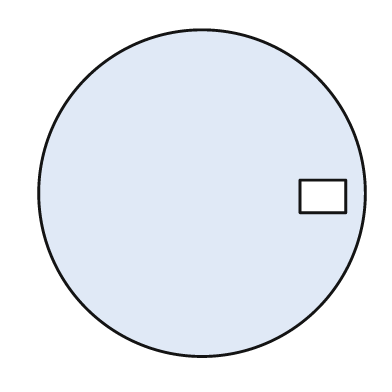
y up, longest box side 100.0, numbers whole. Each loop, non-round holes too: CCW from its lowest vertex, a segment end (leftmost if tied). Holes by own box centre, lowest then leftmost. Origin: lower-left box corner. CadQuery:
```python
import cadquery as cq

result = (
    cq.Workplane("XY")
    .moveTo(50.0, 50.0)
    .circle(50.0)
    .moveTo(80.0, 44.0)
    .lineTo(94.0, 44.0)
    .lineTo(94.0, 54.0)
    .lineTo(80.0, 54.0)
    .close()
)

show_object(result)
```